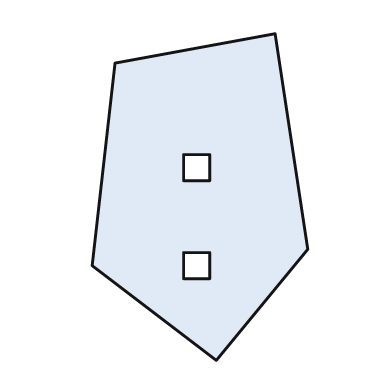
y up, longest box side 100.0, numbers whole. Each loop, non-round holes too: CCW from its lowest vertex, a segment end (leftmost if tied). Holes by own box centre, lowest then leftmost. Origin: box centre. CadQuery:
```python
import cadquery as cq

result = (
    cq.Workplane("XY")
    .moveTo(5.0, -50.0)
    .lineTo(33.0, -16.0)
    .lineTo(23.0, 50.0)
    .lineTo(-26.0, 41.0)
    .lineTo(-33.0, -21.0)
    .close()
    .moveTo(-5.0, -25.0)
    .lineTo(3.0, -25.0)
    .lineTo(3.0, -17.0)
    .lineTo(-5.0, -17.0)
    .close()
    .moveTo(-5.0, 5.0)
    .lineTo(3.0, 5.0)
    .lineTo(3.0, 13.0)
    .lineTo(-5.0, 13.0)
    .close()
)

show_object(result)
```